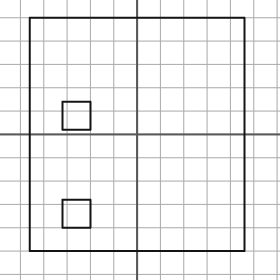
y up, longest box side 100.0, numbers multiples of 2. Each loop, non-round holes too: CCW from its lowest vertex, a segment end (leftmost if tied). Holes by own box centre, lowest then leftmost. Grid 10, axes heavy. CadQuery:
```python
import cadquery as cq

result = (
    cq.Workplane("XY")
    .moveTo(-46.0, -50.0)
    .lineTo(46.0, -50.0)
    .lineTo(46.0, 50.0)
    .lineTo(-46.0, 50.0)
    .close()
    .moveTo(-32.0, -40.0)
    .lineTo(-20.0, -40.0)
    .lineTo(-20.0, -28.0)
    .lineTo(-32.0, -28.0)
    .close()
    .moveTo(-32.0, 2.0)
    .lineTo(-20.0, 2.0)
    .lineTo(-20.0, 14.0)
    .lineTo(-32.0, 14.0)
    .close()
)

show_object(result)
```